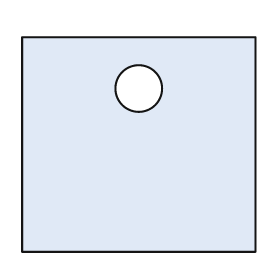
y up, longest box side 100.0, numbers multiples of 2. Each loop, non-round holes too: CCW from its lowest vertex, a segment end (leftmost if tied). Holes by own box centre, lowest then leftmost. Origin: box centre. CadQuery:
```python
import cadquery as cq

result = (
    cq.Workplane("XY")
    .moveTo(-50.0, -46.0)
    .lineTo(50.0, -46.0)
    .lineTo(50.0, 46.0)
    .lineTo(-50.0, 46.0)
    .close()
    .moveTo(0.0, 24.0)
    .circle(10.0)
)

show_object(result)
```